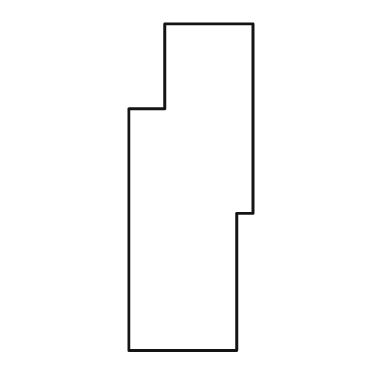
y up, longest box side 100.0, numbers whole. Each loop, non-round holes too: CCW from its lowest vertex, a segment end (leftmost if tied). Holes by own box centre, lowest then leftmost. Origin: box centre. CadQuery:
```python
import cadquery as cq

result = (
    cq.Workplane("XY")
    .moveTo(-19.0, -50.0)
    .lineTo(14.0, -50.0)
    .lineTo(14.0, -8.0)
    .lineTo(19.0, -8.0)
    .lineTo(19.0, 50.0)
    .lineTo(-8.0, 50.0)
    .lineTo(-8.0, 24.0)
    .lineTo(-19.0, 24.0)
    .close()
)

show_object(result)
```